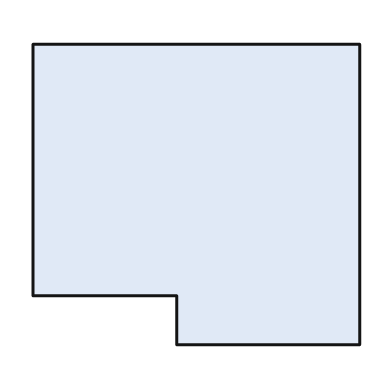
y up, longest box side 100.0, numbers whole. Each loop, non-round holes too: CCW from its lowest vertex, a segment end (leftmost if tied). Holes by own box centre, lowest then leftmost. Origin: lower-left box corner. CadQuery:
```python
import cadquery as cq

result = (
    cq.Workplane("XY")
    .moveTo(44.0, 0.0)
    .lineTo(100.0, 0.0)
    .lineTo(100.0, 92.0)
    .lineTo(0.0, 92.0)
    .lineTo(0.0, 15.0)
    .lineTo(44.0, 15.0)
    .close()
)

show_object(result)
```